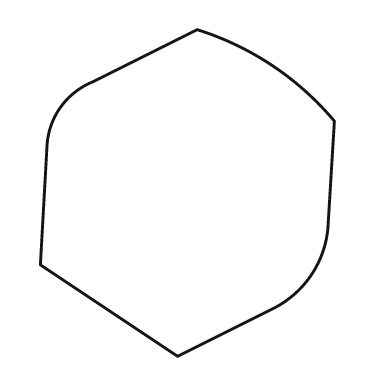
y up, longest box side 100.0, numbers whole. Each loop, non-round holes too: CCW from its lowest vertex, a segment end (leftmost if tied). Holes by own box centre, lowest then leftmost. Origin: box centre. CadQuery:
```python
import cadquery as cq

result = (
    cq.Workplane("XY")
    .moveTo(-3.0, -50.0)
    .lineTo(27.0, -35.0)
    .threePointArc((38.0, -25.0), (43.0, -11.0))
    .lineTo(45.0, 22.0)
    .threePointArc((26.0, 39.0), (3.0, 50.0))
    .lineTo(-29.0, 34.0)
    .threePointArc((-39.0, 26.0), (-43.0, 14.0))
    .lineTo(-45.0, -22.0)
    .close()
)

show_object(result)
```